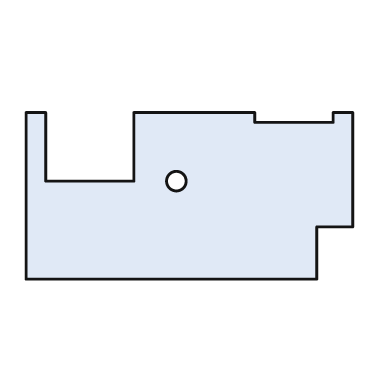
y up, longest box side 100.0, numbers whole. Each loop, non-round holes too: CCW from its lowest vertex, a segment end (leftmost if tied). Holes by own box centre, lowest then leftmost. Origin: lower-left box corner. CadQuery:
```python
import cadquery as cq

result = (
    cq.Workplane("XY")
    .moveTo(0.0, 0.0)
    .lineTo(89.0, 0.0)
    .lineTo(89.0, 16.0)
    .lineTo(100.0, 16.0)
    .lineTo(100.0, 51.0)
    .lineTo(94.0, 51.0)
    .lineTo(94.0, 48.0)
    .lineTo(70.0, 48.0)
    .lineTo(70.0, 51.0)
    .lineTo(33.0, 51.0)
    .lineTo(33.0, 30.0)
    .lineTo(6.0, 30.0)
    .lineTo(6.0, 51.0)
    .lineTo(0.0, 51.0)
    .close()
    .moveTo(46.0, 30.0)
    .circle(3.0)
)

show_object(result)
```